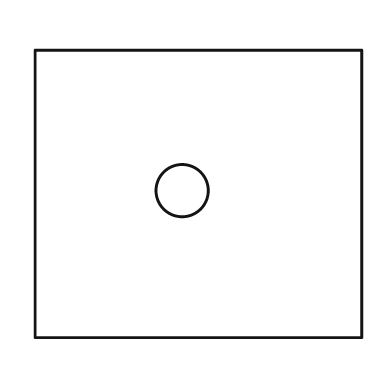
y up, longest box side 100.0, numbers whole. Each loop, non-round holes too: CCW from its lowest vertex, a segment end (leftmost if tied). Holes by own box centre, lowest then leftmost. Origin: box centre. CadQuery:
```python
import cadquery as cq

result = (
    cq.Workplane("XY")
    .moveTo(-50.0, -44.0)
    .lineTo(50.0, -44.0)
    .lineTo(50.0, 44.0)
    .lineTo(-50.0, 44.0)
    .close()
    .moveTo(-5.0, 1.0)
    .circle(8.0)
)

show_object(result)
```